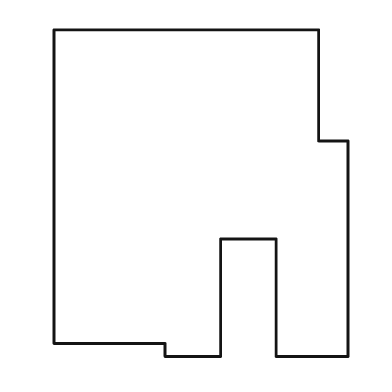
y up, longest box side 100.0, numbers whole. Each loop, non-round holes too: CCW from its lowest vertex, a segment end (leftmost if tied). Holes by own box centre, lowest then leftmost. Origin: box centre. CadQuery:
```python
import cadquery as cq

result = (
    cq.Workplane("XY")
    .moveTo(-11.0, -50.0)
    .lineTo(6.0, -50.0)
    .lineTo(6.0, -14.0)
    .lineTo(23.0, -14.0)
    .lineTo(23.0, -50.0)
    .lineTo(45.0, -50.0)
    .lineTo(45.0, 16.0)
    .lineTo(36.0, 16.0)
    .lineTo(36.0, 50.0)
    .lineTo(-45.0, 50.0)
    .lineTo(-45.0, -46.0)
    .lineTo(-11.0, -46.0)
    .close()
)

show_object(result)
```